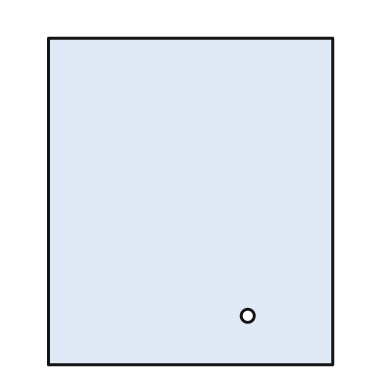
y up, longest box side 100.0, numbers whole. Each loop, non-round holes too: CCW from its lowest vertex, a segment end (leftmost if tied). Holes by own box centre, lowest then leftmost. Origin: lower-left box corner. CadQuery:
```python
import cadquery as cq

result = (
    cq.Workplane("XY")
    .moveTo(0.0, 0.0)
    .lineTo(87.0, 0.0)
    .lineTo(87.0, 100.0)
    .lineTo(0.0, 100.0)
    .close()
    .moveTo(61.0, 15.0)
    .circle(2.0)
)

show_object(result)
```